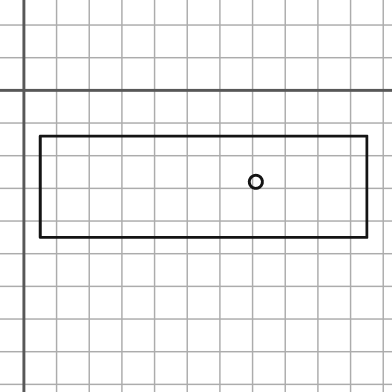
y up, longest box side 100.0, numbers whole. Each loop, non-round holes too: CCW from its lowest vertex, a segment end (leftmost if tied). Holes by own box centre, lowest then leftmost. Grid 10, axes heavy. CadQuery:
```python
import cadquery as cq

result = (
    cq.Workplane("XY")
    .moveTo(5.0, -45.0)
    .lineTo(105.0, -45.0)
    .lineTo(105.0, -14.0)
    .lineTo(5.0, -14.0)
    .close()
    .moveTo(71.0, -28.0)
    .circle(2.0)
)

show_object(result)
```